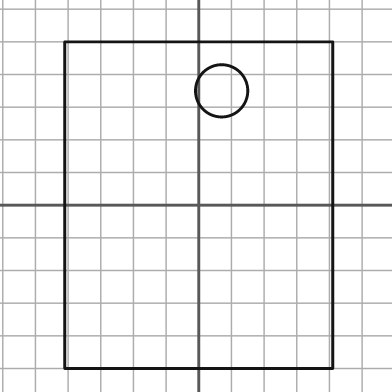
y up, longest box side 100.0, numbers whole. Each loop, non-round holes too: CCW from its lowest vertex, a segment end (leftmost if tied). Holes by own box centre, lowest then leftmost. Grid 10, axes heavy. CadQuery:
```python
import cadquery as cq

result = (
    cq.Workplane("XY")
    .moveTo(-41.0, -50.0)
    .lineTo(41.0, -50.0)
    .lineTo(41.0, 50.0)
    .lineTo(-41.0, 50.0)
    .close()
    .moveTo(7.0, 35.0)
    .circle(8.0)
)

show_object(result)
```